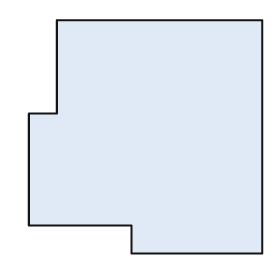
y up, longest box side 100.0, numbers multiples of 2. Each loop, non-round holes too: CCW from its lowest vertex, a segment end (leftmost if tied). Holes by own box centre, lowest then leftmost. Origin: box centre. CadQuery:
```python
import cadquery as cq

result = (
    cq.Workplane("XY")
    .moveTo(-6.0, -50.0)
    .lineTo(50.0, -50.0)
    .lineTo(50.0, 50.0)
    .lineTo(-38.0, 50.0)
    .lineTo(-38.0, 10.0)
    .lineTo(-50.0, 10.0)
    .lineTo(-50.0, -38.0)
    .lineTo(-6.0, -38.0)
    .close()
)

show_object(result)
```